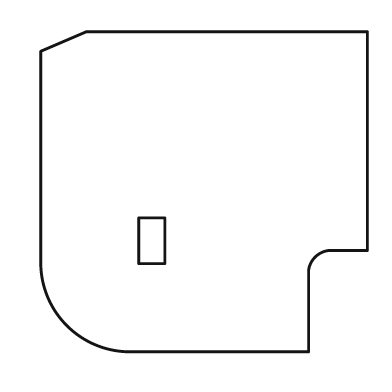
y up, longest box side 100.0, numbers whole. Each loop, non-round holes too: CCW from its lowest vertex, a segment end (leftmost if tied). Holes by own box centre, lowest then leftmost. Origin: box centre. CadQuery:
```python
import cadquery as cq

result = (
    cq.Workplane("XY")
    .moveTo(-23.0, -49.0)
    .lineTo(32.0, -49.0)
    .lineTo(32.0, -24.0)
    .threePointArc((34.0, -20.0), (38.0, -18.0))
    .lineTo(50.0, -18.0)
    .lineTo(50.0, 49.0)
    .lineTo(-36.0, 49.0)
    .lineTo(-50.0, 43.0)
    .lineTo(-50.0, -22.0)
    .threePointArc((-42.0, -41.0), (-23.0, -49.0))
    .close()
    .moveTo(-20.0, -22.0)
    .lineTo(-12.0, -22.0)
    .lineTo(-12.0, -8.0)
    .lineTo(-20.0, -8.0)
    .close()
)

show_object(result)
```